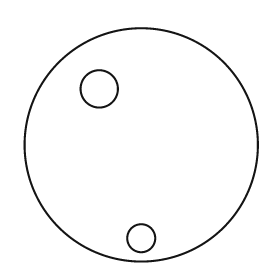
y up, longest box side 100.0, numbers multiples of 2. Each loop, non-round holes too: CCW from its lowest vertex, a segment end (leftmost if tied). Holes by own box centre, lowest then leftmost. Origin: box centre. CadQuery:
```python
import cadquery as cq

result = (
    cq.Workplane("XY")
    .moveTo(0.0, 0.0)
    .circle(50.0)
    .moveTo(0.0, -40.0)
    .circle(6.0)
    .moveTo(-18.0, 24.0)
    .circle(8.0)
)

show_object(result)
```